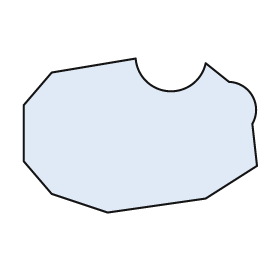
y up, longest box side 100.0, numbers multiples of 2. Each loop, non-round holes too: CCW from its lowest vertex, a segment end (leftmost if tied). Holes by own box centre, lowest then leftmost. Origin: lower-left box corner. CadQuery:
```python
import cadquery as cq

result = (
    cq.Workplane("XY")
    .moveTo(36.0, 0.0)
    .lineTo(78.0, 6.0)
    .lineTo(100.0, 20.0)
    .lineTo(98.0, 38.0)
    .threePointArc((98.0, 50.0), (88.0, 56.0))
    .lineTo(78.0, 64.0)
    .threePointArc((62.0, 52.0), (48.0, 66.0))
    .lineTo(12.0, 60.0)
    .lineTo(0.0, 46.0)
    .lineTo(0.0, 22.0)
    .lineTo(12.0, 8.0)
    .close()
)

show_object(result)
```